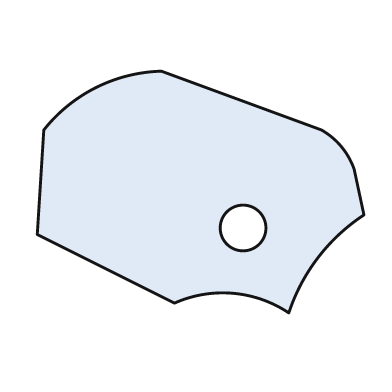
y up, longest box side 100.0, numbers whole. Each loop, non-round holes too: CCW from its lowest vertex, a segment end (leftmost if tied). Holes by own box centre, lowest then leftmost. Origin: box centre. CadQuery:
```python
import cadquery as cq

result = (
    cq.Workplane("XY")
    .moveTo(27.0, -37.0)
    .threePointArc((36.0, -20.0), (50.0, -7.0))
    .lineTo(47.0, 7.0)
    .threePointArc((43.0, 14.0), (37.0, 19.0))
    .lineTo(-12.0, 37.0)
    .threePointArc((-32.0, 32.0), (-48.0, 19.0))
    .lineTo(-50.0, -13.0)
    .lineTo(-8.0, -34.0)
    .threePointArc((10.0, -31.0), (27.0, -37.0))
    .close()
    .moveTo(13.0, -11.0)
    .circle(7.0)
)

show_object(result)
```